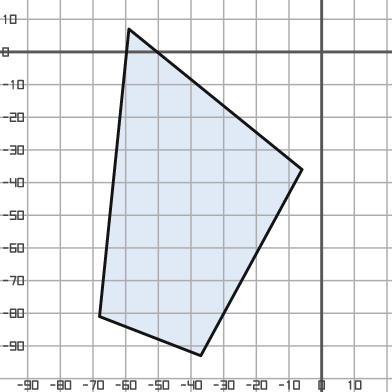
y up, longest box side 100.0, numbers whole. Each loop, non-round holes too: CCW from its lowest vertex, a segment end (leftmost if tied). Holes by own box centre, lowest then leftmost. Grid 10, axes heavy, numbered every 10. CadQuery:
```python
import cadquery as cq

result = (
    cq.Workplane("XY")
    .moveTo(-37.0, -93.0)
    .lineTo(-6.0, -36.0)
    .lineTo(-59.0, 7.0)
    .lineTo(-68.0, -81.0)
    .close()
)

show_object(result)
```